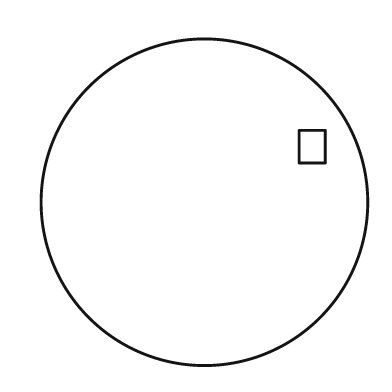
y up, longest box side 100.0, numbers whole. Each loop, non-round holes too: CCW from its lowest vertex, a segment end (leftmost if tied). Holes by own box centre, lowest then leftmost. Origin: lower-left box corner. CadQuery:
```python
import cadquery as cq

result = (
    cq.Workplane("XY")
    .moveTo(50.0, 50.0)
    .circle(50.0)
    .moveTo(79.0, 62.0)
    .lineTo(87.0, 62.0)
    .lineTo(87.0, 72.0)
    .lineTo(79.0, 72.0)
    .close()
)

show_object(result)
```